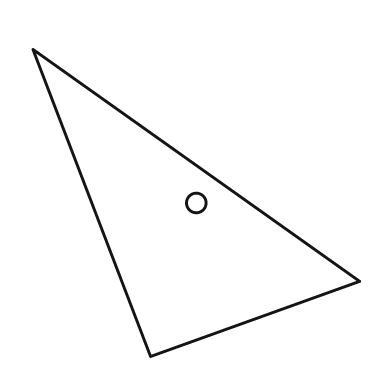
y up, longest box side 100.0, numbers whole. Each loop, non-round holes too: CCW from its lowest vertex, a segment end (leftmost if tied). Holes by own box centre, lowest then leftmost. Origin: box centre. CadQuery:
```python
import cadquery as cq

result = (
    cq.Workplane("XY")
    .moveTo(-14.0, -47.0)
    .lineTo(50.0, -24.0)
    .lineTo(-50.0, 47.0)
    .close()
    .moveTo(0.0, 0.0)
    .circle(3.0)
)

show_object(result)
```